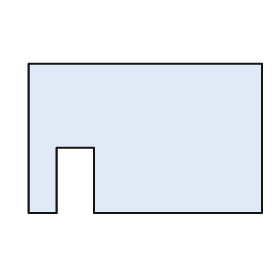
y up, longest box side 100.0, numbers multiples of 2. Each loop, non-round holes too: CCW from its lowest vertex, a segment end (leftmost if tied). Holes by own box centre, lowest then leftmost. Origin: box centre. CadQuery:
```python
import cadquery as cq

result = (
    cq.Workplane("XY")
    .moveTo(-50.0, -32.0)
    .lineTo(-38.0, -32.0)
    .lineTo(-38.0, -4.0)
    .lineTo(-22.0, -4.0)
    .lineTo(-22.0, -32.0)
    .lineTo(50.0, -32.0)
    .lineTo(50.0, 32.0)
    .lineTo(-50.0, 32.0)
    .close()
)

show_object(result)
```